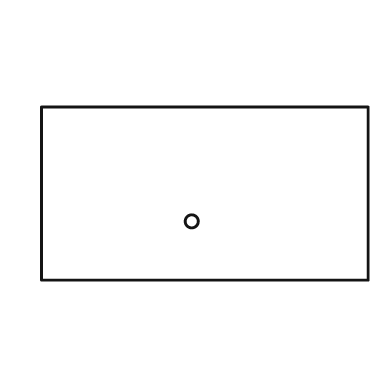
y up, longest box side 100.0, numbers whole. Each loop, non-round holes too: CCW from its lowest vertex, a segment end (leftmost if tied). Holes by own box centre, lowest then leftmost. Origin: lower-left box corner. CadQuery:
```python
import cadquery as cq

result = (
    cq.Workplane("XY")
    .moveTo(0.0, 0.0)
    .lineTo(100.0, 0.0)
    .lineTo(100.0, 53.0)
    .lineTo(0.0, 53.0)
    .close()
    .moveTo(46.0, 18.0)
    .circle(2.0)
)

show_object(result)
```